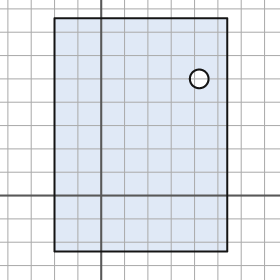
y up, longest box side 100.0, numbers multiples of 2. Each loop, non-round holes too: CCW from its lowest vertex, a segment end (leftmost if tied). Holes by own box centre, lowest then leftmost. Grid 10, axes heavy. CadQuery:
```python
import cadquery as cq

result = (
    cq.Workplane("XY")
    .moveTo(-20.0, -24.0)
    .lineTo(54.0, -24.0)
    .lineTo(54.0, 76.0)
    .lineTo(-20.0, 76.0)
    .close()
    .moveTo(42.0, 50.0)
    .circle(4.0)
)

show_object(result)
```